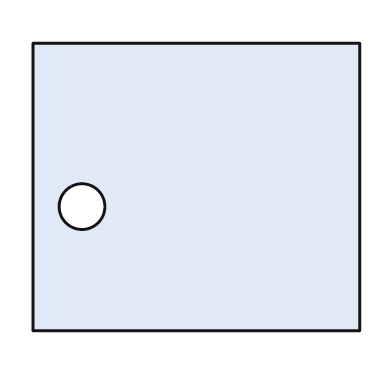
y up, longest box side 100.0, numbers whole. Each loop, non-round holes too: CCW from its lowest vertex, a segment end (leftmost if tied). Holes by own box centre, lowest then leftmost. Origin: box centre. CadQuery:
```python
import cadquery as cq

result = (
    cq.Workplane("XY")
    .moveTo(-50.0, -44.0)
    .lineTo(50.0, -44.0)
    .lineTo(50.0, 44.0)
    .lineTo(-50.0, 44.0)
    .close()
    .moveTo(-35.0, -6.0)
    .circle(7.0)
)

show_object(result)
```